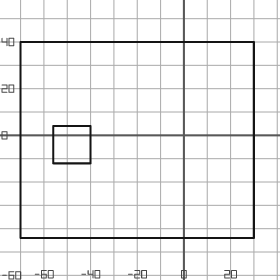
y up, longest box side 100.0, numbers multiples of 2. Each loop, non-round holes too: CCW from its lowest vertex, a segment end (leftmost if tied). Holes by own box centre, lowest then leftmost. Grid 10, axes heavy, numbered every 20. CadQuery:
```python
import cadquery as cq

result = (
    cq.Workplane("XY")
    .moveTo(-70.0, -44.0)
    .lineTo(30.0, -44.0)
    .lineTo(30.0, 40.0)
    .lineTo(-70.0, 40.0)
    .close()
    .moveTo(-56.0, -12.0)
    .lineTo(-40.0, -12.0)
    .lineTo(-40.0, 4.0)
    .lineTo(-56.0, 4.0)
    .close()
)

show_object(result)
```